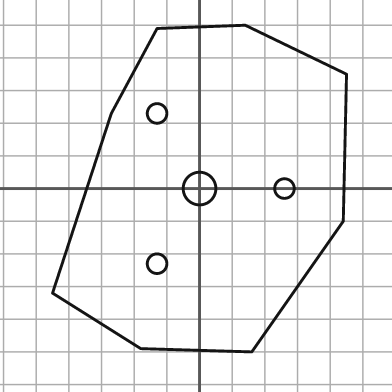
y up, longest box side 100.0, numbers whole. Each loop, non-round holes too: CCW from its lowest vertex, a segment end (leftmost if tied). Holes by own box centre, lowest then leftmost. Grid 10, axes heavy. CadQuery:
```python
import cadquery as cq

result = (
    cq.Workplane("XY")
    .moveTo(16.0, -50.0)
    .lineTo(44.0, -10.0)
    .lineTo(45.0, 35.0)
    .lineTo(14.0, 50.0)
    .lineTo(-13.0, 49.0)
    .lineTo(-27.0, 23.0)
    .lineTo(-45.0, -32.0)
    .lineTo(-18.0, -49.0)
    .close()
    .moveTo(-13.0, -23.0)
    .circle(3.0)
    .moveTo(0.0, 0.0)
    .circle(5.0)
    .moveTo(26.0, 0.0)
    .circle(3.0)
    .moveTo(-13.0, 23.0)
    .circle(3.0)
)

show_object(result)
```